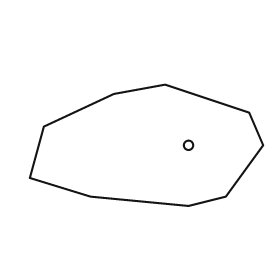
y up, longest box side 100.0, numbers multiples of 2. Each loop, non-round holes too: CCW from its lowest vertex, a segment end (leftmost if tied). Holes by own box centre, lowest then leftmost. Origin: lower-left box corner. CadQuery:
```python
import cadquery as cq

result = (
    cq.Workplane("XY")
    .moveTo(68.0, 0.0)
    .lineTo(84.0, 4.0)
    .lineTo(100.0, 26.0)
    .lineTo(94.0, 40.0)
    .lineTo(58.0, 52.0)
    .lineTo(36.0, 48.0)
    .lineTo(6.0, 34.0)
    .lineTo(0.0, 12.0)
    .lineTo(26.0, 4.0)
    .close()
    .moveTo(68.0, 26.0)
    .circle(2.0)
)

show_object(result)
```